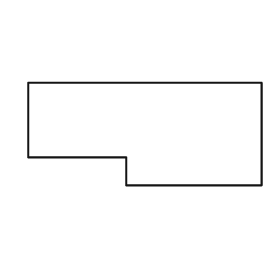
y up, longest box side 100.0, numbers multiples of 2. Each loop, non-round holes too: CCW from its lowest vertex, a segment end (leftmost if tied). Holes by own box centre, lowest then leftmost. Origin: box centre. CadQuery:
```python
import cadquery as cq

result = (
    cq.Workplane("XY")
    .moveTo(-8.0, -22.0)
    .lineTo(50.0, -22.0)
    .lineTo(50.0, 22.0)
    .lineTo(-50.0, 22.0)
    .lineTo(-50.0, -10.0)
    .lineTo(-8.0, -10.0)
    .close()
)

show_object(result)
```